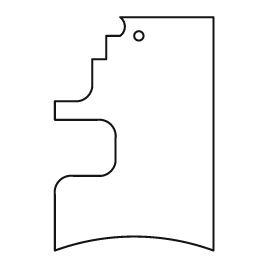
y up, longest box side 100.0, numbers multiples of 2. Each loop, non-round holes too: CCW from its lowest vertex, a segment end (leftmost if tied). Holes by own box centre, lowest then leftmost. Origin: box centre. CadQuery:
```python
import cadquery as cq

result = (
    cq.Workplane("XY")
    .moveTo(-34.0, -50.0)
    .threePointArc((0.0, -44.0), (34.0, -50.0))
    .lineTo(34.0, 50.0)
    .lineTo(-6.0, 50.0)
    .threePointArc((-4.0, 46.0), (-6.0, 42.0))
    .lineTo(-12.0, 42.0)
    .lineTo(-12.0, 32.0)
    .lineTo(-18.0, 32.0)
    .lineTo(-18.0, 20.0)
    .threePointArc((-20.0, 16.0), (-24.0, 14.0))
    .lineTo(-34.0, 14.0)
    .lineTo(-34.0, 6.0)
    .lineTo(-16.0, 6.0)
    .threePointArc((-10.0, 4.0), (-8.0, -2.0))
    .lineTo(-8.0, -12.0)
    .threePointArc((-10.0, -16.0), (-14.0, -18.0))
    .lineTo(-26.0, -18.0)
    .threePointArc((-32.0, -20.0), (-34.0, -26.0))
    .close()
    .moveTo(2.0, 42.0)
    .circle(2.0)
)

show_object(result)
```